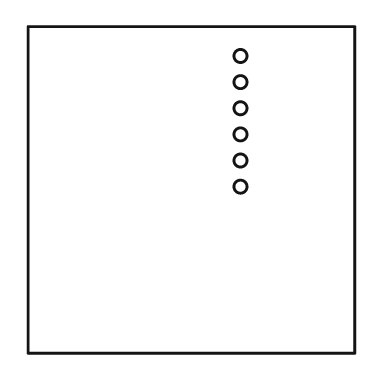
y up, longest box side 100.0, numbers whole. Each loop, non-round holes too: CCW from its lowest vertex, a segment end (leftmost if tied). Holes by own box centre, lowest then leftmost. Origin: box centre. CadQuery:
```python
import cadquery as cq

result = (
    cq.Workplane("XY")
    .moveTo(-50.0, -50.0)
    .lineTo(50.0, -50.0)
    .lineTo(50.0, 50.0)
    .lineTo(-50.0, 50.0)
    .close()
    .moveTo(15.0, 1.0)
    .circle(2.0)
    .moveTo(15.0, 9.0)
    .circle(2.0)
    .moveTo(15.0, 17.0)
    .circle(2.0)
    .moveTo(15.0, 25.0)
    .circle(2.0)
    .moveTo(15.0, 33.0)
    .circle(2.0)
    .moveTo(15.0, 41.0)
    .circle(2.0)
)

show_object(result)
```